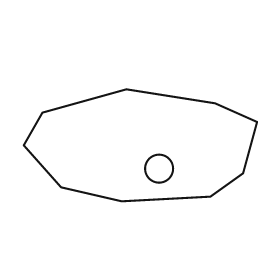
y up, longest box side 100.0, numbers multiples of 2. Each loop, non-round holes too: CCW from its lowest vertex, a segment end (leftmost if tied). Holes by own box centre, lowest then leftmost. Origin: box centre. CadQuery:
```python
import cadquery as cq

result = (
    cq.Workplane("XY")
    .moveTo(-8.0, -24.0)
    .lineTo(30.0, -22.0)
    .lineTo(44.0, -12.0)
    .lineTo(50.0, 10.0)
    .lineTo(32.0, 18.0)
    .lineTo(-6.0, 24.0)
    .lineTo(-42.0, 14.0)
    .lineTo(-50.0, 0.0)
    .lineTo(-34.0, -18.0)
    .close()
    .moveTo(8.0, -10.0)
    .circle(6.0)
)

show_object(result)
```